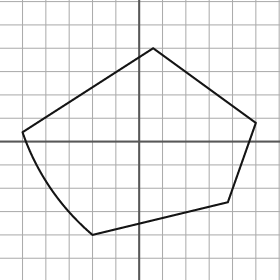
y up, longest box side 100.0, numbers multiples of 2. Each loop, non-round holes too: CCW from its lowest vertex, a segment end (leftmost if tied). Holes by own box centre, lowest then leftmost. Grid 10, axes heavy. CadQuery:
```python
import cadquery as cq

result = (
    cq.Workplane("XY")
    .moveTo(-20.0, -40.0)
    .lineTo(38.0, -26.0)
    .lineTo(50.0, 8.0)
    .lineTo(6.0, 40.0)
    .lineTo(-50.0, 4.0)
    .threePointArc((-38.0, -20.0), (-20.0, -40.0))
    .close()
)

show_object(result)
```